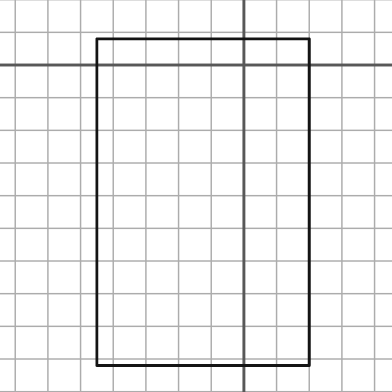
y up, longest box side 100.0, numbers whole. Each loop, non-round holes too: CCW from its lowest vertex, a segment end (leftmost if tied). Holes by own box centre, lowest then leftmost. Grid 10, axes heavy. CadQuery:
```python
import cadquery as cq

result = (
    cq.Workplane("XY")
    .moveTo(-45.0, -92.0)
    .lineTo(20.0, -92.0)
    .lineTo(20.0, 8.0)
    .lineTo(-45.0, 8.0)
    .close()
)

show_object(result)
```